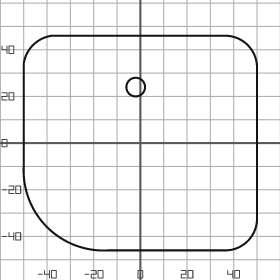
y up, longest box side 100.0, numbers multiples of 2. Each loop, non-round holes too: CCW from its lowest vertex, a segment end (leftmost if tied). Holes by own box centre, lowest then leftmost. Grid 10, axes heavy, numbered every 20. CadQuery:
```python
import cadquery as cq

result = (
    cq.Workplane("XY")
    .moveTo(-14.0, -46.0)
    .lineTo(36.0, -46.0)
    .threePointArc((46.0, -42.0), (50.0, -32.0))
    .lineTo(50.0, 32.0)
    .threePointArc((46.0, 42.0), (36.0, 46.0))
    .lineTo(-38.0, 46.0)
    .threePointArc((-46.0, 42.0), (-50.0, 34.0))
    .lineTo(-50.0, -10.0)
    .threePointArc((-40.0, -36.0), (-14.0, -46.0))
    .close()
    .moveTo(-2.0, 24.0)
    .circle(4.0)
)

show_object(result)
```